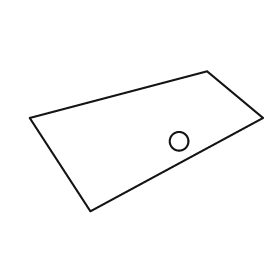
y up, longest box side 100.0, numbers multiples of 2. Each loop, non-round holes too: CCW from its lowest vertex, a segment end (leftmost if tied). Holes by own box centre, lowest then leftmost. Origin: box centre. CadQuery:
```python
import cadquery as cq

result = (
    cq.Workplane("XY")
    .moveTo(-24.0, -30.0)
    .lineTo(50.0, 10.0)
    .lineTo(26.0, 30.0)
    .lineTo(-50.0, 10.0)
    .close()
    .moveTo(14.0, 0.0)
    .circle(4.0)
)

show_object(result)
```